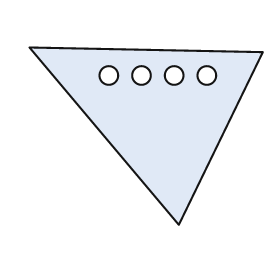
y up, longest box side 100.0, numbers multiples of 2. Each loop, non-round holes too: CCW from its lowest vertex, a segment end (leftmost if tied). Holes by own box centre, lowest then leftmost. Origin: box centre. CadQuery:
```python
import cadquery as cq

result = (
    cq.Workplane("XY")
    .moveTo(14.0, -38.0)
    .lineTo(50.0, 36.0)
    .lineTo(-50.0, 38.0)
    .close()
    .moveTo(-16.0, 26.0)
    .circle(4.0)
    .moveTo(-2.0, 26.0)
    .circle(4.0)
    .moveTo(12.0, 26.0)
    .circle(4.0)
    .moveTo(26.0, 26.0)
    .circle(4.0)
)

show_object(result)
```